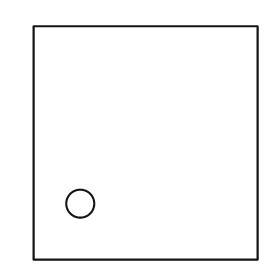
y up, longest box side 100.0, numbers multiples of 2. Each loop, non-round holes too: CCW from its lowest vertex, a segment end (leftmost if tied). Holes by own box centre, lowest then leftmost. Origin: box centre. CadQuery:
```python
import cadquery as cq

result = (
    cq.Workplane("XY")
    .moveTo(-48.0, -50.0)
    .lineTo(48.0, -50.0)
    .lineTo(48.0, 50.0)
    .lineTo(-48.0, 50.0)
    .close()
    .moveTo(-28.0, -26.0)
    .circle(6.0)
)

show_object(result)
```